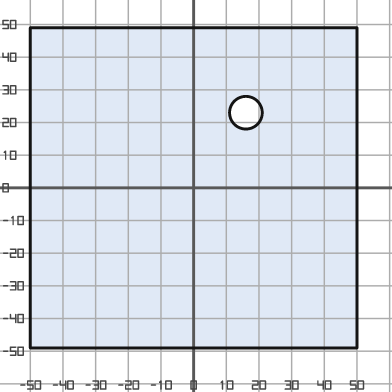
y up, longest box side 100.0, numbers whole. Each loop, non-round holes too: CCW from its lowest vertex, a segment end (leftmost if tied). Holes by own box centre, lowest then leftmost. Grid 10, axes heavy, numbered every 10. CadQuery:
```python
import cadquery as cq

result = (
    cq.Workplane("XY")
    .moveTo(-50.0, -49.0)
    .lineTo(50.0, -49.0)
    .lineTo(50.0, 49.0)
    .lineTo(-50.0, 49.0)
    .close()
    .moveTo(16.0, 23.0)
    .circle(5.0)
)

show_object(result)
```